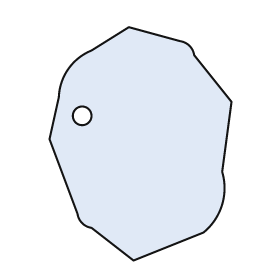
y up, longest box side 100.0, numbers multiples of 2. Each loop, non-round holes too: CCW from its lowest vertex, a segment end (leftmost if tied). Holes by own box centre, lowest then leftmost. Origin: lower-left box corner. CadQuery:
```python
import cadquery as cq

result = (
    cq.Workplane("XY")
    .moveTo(36.0, 0.0)
    .lineTo(66.0, 12.0)
    .threePointArc((74.0, 24.0), (74.0, 38.0))
    .lineTo(78.0, 68.0)
    .lineTo(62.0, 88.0)
    .threePointArc((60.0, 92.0), (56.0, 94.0))
    .lineTo(34.0, 100.0)
    .lineTo(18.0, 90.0)
    .threePointArc((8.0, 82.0), (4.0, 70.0))
    .lineTo(0.0, 52.0)
    .lineTo(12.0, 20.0)
    .threePointArc((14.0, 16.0), (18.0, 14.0))
    .close()
    .moveTo(14.0, 62.0)
    .circle(4.0)
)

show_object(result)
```